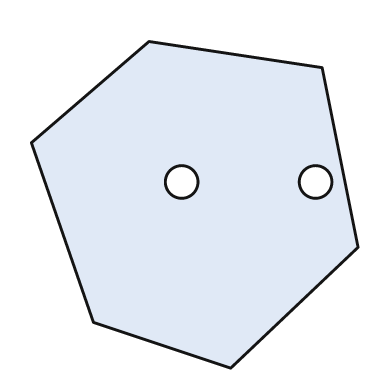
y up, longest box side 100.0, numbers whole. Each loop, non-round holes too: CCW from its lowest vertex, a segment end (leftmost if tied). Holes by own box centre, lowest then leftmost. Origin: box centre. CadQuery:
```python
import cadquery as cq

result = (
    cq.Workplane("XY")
    .moveTo(11.0, -50.0)
    .lineTo(50.0, -13.0)
    .lineTo(39.0, 42.0)
    .lineTo(-14.0, 50.0)
    .lineTo(-50.0, 19.0)
    .lineTo(-31.0, -36.0)
    .close()
    .moveTo(-4.0, 7.0)
    .circle(5.0)
    .moveTo(37.0, 7.0)
    .circle(5.0)
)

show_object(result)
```